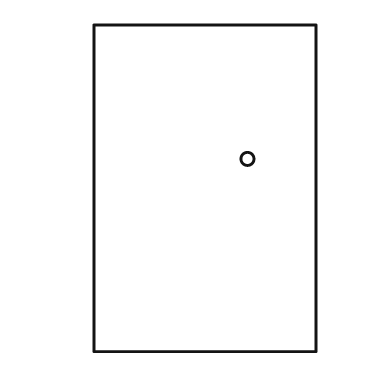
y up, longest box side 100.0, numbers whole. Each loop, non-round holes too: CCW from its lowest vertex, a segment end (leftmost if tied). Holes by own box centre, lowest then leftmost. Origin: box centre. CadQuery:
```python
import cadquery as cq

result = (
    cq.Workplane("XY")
    .moveTo(-34.0, -50.0)
    .lineTo(34.0, -50.0)
    .lineTo(34.0, 50.0)
    .lineTo(-34.0, 50.0)
    .close()
    .moveTo(13.0, 9.0)
    .circle(2.0)
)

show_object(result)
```